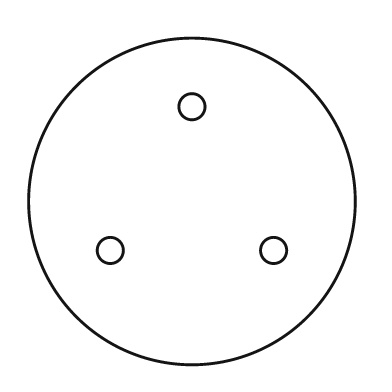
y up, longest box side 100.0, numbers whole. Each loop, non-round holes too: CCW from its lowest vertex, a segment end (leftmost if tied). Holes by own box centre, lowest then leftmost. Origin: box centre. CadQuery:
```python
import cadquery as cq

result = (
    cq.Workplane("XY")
    .moveTo(0.0, 0.0)
    .circle(50.0)
    .moveTo(-25.0, -15.0)
    .circle(4.0)
    .moveTo(25.0, -15.0)
    .circle(4.0)
    .moveTo(0.0, 29.0)
    .circle(4.0)
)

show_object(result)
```